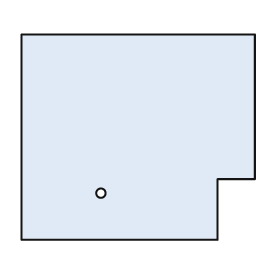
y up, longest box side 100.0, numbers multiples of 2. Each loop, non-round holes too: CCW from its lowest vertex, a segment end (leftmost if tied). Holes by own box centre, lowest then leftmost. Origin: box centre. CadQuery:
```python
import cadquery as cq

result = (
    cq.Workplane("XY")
    .moveTo(-50.0, -44.0)
    .lineTo(34.0, -44.0)
    .lineTo(34.0, -18.0)
    .lineTo(50.0, -18.0)
    .lineTo(50.0, 44.0)
    .lineTo(-50.0, 44.0)
    .close()
    .moveTo(-16.0, -24.0)
    .circle(2.0)
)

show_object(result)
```